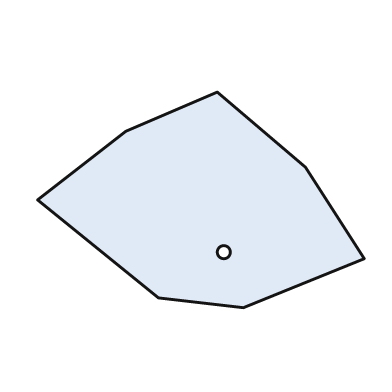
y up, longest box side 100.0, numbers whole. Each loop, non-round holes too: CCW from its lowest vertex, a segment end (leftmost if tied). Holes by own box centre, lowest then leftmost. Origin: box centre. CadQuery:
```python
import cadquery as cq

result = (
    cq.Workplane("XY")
    .moveTo(13.0, -33.0)
    .lineTo(50.0, -18.0)
    .lineTo(32.0, 10.0)
    .lineTo(5.0, 33.0)
    .lineTo(-23.0, 21.0)
    .lineTo(-50.0, 0.0)
    .lineTo(-13.0, -30.0)
    .close()
    .moveTo(7.0, -16.0)
    .circle(2.0)
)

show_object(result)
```